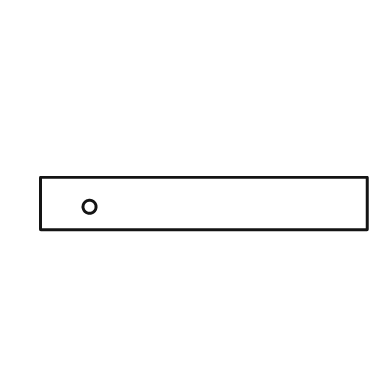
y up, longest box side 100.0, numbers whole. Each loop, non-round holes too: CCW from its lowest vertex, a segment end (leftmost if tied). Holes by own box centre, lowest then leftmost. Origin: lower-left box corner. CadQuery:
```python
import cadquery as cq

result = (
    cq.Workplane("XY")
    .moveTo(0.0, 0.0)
    .lineTo(100.0, 0.0)
    .lineTo(100.0, 16.0)
    .lineTo(0.0, 16.0)
    .close()
    .moveTo(15.0, 7.0)
    .circle(2.0)
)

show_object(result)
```